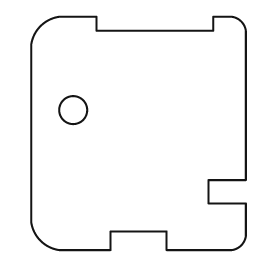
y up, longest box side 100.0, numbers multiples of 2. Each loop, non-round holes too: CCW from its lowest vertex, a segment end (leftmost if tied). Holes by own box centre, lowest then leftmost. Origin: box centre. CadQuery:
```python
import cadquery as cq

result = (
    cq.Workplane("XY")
    .moveTo(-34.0, -50.0)
    .lineTo(-12.0, -50.0)
    .lineTo(-12.0, -42.0)
    .lineTo(12.0, -42.0)
    .lineTo(12.0, -50.0)
    .lineTo(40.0, -50.0)
    .threePointArc((44.0, -48.0), (46.0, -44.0))
    .lineTo(46.0, -30.0)
    .lineTo(30.0, -30.0)
    .lineTo(30.0, -20.0)
    .lineTo(46.0, -20.0)
    .lineTo(46.0, 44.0)
    .threePointArc((44.0, 48.0), (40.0, 50.0))
    .lineTo(32.0, 50.0)
    .lineTo(32.0, 44.0)
    .lineTo(-18.0, 44.0)
    .lineTo(-18.0, 50.0)
    .lineTo(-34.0, 50.0)
    .threePointArc((-42.0, 46.0), (-46.0, 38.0))
    .lineTo(-46.0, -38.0)
    .threePointArc((-42.0, -46.0), (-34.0, -50.0))
    .close()
    .moveTo(-28.0, 10.0)
    .circle(6.0)
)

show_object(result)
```